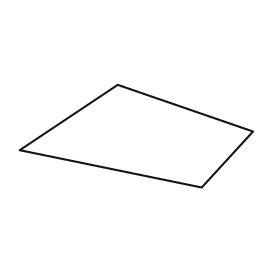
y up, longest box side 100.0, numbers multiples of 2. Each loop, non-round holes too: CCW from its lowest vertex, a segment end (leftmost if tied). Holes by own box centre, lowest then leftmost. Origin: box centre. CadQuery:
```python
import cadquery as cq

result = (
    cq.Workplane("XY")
    .moveTo(28.0, -22.0)
    .lineTo(50.0, 2.0)
    .lineTo(-8.0, 22.0)
    .lineTo(-50.0, -6.0)
    .close()
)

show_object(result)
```